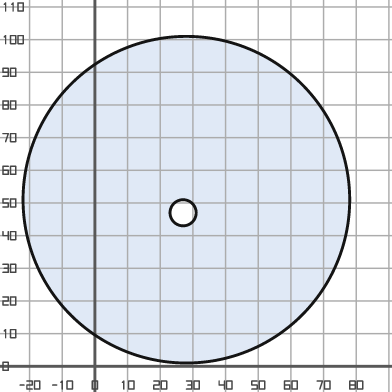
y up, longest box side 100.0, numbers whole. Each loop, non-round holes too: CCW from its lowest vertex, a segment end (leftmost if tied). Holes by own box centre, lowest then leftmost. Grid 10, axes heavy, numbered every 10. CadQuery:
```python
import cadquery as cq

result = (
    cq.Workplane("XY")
    .moveTo(28.0, 51.0)
    .circle(50.0)
    .moveTo(27.0, 47.0)
    .circle(4.0)
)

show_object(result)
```